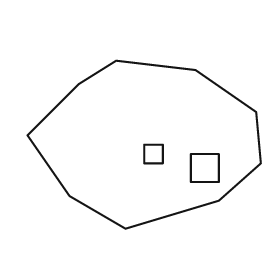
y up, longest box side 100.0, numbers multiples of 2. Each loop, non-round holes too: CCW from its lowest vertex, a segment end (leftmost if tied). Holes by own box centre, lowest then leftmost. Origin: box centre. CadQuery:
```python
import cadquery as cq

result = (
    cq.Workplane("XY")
    .moveTo(-8.0, -36.0)
    .lineTo(32.0, -24.0)
    .lineTo(50.0, -8.0)
    .lineTo(48.0, 14.0)
    .lineTo(22.0, 32.0)
    .lineTo(-12.0, 36.0)
    .lineTo(-28.0, 26.0)
    .lineTo(-50.0, 4.0)
    .lineTo(-32.0, -22.0)
    .close()
    .moveTo(20.0, -16.0)
    .lineTo(32.0, -16.0)
    .lineTo(32.0, -4.0)
    .lineTo(20.0, -4.0)
    .close()
    .moveTo(0.0, -8.0)
    .lineTo(8.0, -8.0)
    .lineTo(8.0, 0.0)
    .lineTo(0.0, 0.0)
    .close()
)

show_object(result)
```